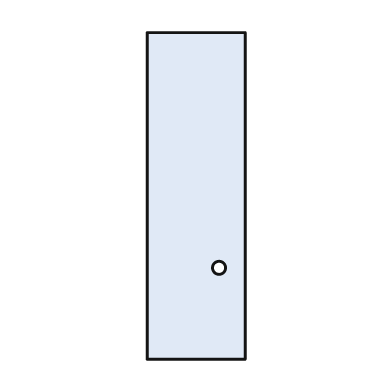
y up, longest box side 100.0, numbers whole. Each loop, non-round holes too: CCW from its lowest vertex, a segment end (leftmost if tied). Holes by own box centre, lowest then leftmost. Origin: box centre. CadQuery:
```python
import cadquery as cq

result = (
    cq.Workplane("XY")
    .moveTo(-15.0, -50.0)
    .lineTo(15.0, -50.0)
    .lineTo(15.0, 50.0)
    .lineTo(-15.0, 50.0)
    .close()
    .moveTo(7.0, -22.0)
    .circle(2.0)
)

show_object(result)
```